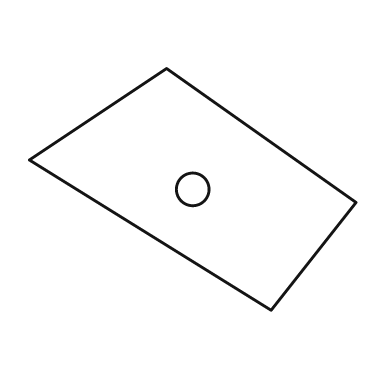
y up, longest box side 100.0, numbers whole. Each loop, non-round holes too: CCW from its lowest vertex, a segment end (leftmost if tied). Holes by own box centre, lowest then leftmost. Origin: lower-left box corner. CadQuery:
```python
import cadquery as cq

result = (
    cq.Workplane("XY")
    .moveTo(74.0, 0.0)
    .lineTo(100.0, 33.0)
    .lineTo(42.0, 74.0)
    .lineTo(0.0, 46.0)
    .close()
    .moveTo(50.0, 37.0)
    .circle(5.0)
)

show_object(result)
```